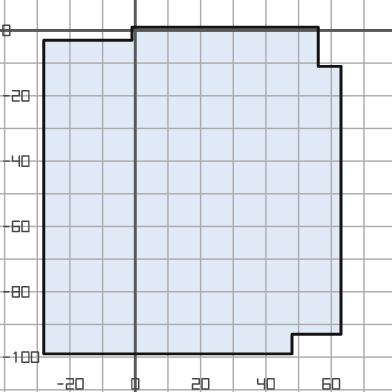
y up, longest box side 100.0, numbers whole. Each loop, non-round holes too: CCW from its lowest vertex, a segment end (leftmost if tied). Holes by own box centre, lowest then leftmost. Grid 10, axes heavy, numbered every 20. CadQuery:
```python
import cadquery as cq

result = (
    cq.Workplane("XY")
    .moveTo(-28.0, -99.0)
    .lineTo(48.0, -99.0)
    .lineTo(48.0, -93.0)
    .lineTo(63.0, -93.0)
    .lineTo(63.0, -11.0)
    .lineTo(56.0, -11.0)
    .lineTo(56.0, 1.0)
    .lineTo(-1.0, 1.0)
    .lineTo(-1.0, -3.0)
    .lineTo(-28.0, -3.0)
    .close()
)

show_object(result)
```